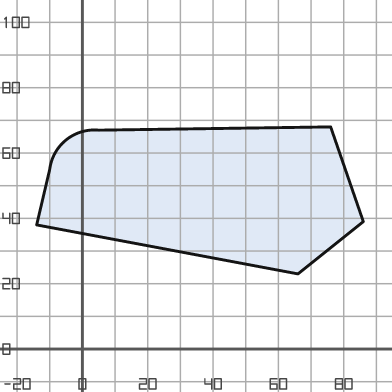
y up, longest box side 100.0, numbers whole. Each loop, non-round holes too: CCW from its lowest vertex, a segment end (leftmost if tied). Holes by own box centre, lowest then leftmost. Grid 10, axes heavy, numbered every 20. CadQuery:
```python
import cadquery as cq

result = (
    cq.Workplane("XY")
    .moveTo(66.0, 23.0)
    .lineTo(86.0, 39.0)
    .lineTo(76.0, 68.0)
    .lineTo(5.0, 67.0)
    .threePointArc((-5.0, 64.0), (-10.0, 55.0))
    .lineTo(-14.0, 38.0)
    .close()
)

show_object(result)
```